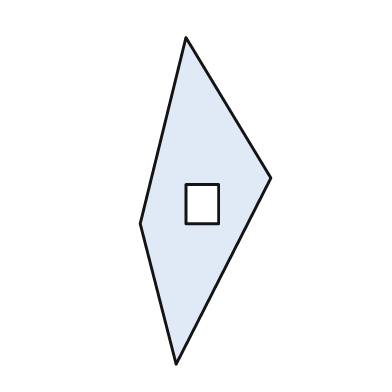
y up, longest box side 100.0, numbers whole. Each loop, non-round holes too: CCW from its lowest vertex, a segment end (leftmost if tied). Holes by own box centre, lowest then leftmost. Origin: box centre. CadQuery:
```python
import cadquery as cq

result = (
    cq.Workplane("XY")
    .moveTo(-9.0, -50.0)
    .lineTo(20.0, 7.0)
    .lineTo(-6.0, 50.0)
    .lineTo(-20.0, -7.0)
    .close()
    .moveTo(-6.0, -7.0)
    .lineTo(4.0, -7.0)
    .lineTo(4.0, 5.0)
    .lineTo(-6.0, 5.0)
    .close()
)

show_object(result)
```